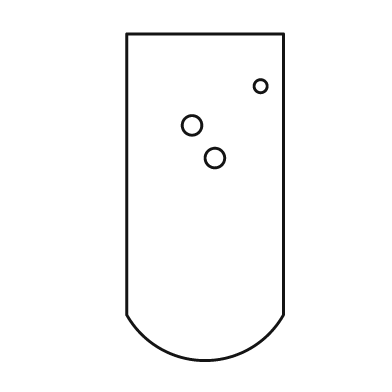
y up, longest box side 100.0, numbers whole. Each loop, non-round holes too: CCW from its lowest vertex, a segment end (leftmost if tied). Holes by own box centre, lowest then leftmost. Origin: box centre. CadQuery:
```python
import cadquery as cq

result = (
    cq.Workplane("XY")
    .moveTo(-24.0, -36.0)
    .threePointArc((0.0, -50.0), (24.0, -36.0))
    .lineTo(24.0, 50.0)
    .lineTo(-24.0, 50.0)
    .close()
    .moveTo(3.0, 12.0)
    .circle(3.0)
    .moveTo(-4.0, 22.0)
    .circle(3.0)
    .moveTo(17.0, 34.0)
    .circle(2.0)
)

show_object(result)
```